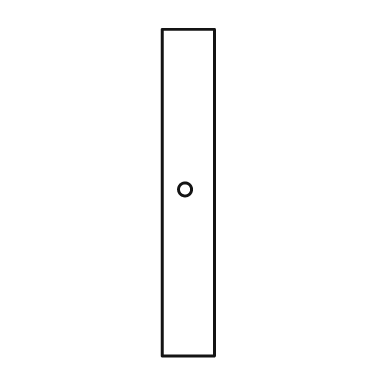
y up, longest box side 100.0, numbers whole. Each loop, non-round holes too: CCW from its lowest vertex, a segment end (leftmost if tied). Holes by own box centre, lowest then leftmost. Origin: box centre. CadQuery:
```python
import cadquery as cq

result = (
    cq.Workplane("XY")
    .moveTo(-8.0, -50.0)
    .lineTo(8.0, -50.0)
    .lineTo(8.0, 50.0)
    .lineTo(-8.0, 50.0)
    .close()
    .moveTo(-1.0, 1.0)
    .circle(2.0)
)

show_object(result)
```